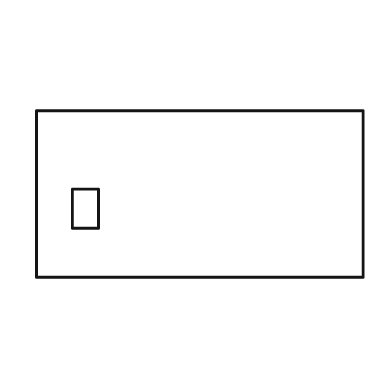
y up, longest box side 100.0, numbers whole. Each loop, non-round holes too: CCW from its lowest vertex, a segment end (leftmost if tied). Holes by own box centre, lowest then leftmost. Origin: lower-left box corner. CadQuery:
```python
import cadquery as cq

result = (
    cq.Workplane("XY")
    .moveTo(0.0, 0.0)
    .lineTo(100.0, 0.0)
    .lineTo(100.0, 51.0)
    .lineTo(0.0, 51.0)
    .close()
    .moveTo(11.0, 15.0)
    .lineTo(19.0, 15.0)
    .lineTo(19.0, 27.0)
    .lineTo(11.0, 27.0)
    .close()
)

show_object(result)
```